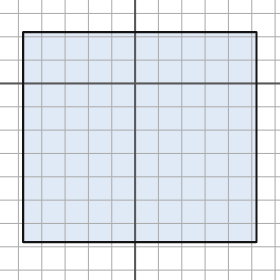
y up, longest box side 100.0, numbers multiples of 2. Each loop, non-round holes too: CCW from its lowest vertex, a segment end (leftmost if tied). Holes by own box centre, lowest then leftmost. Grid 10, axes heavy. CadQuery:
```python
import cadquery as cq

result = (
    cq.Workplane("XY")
    .moveTo(-48.0, -68.0)
    .lineTo(52.0, -68.0)
    .lineTo(52.0, 22.0)
    .lineTo(-48.0, 22.0)
    .close()
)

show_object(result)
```